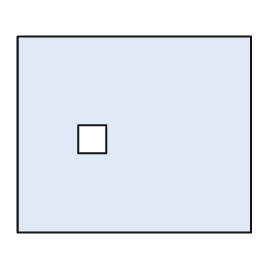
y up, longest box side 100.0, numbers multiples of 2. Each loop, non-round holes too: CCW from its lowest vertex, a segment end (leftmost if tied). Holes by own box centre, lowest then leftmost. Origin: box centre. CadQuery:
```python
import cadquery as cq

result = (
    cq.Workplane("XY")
    .moveTo(-50.0, -42.0)
    .lineTo(50.0, -42.0)
    .lineTo(50.0, 42.0)
    .lineTo(-50.0, 42.0)
    .close()
    .moveTo(-24.0, -8.0)
    .lineTo(-12.0, -8.0)
    .lineTo(-12.0, 4.0)
    .lineTo(-24.0, 4.0)
    .close()
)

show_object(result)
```